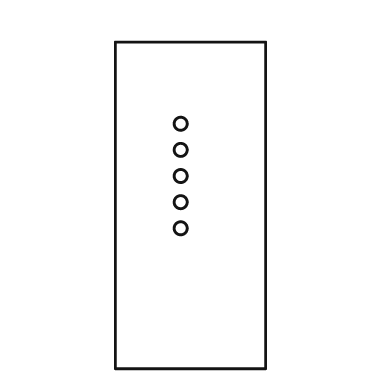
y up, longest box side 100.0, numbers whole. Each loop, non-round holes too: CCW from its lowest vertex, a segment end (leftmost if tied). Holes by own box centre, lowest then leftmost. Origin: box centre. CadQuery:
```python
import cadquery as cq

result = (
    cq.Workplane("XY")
    .moveTo(-23.0, -50.0)
    .lineTo(23.0, -50.0)
    .lineTo(23.0, 50.0)
    .lineTo(-23.0, 50.0)
    .close()
    .moveTo(-3.0, -7.0)
    .circle(2.0)
    .moveTo(-3.0, 1.0)
    .circle(2.0)
    .moveTo(-3.0, 9.0)
    .circle(2.0)
    .moveTo(-3.0, 17.0)
    .circle(2.0)
    .moveTo(-3.0, 25.0)
    .circle(2.0)
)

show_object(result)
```